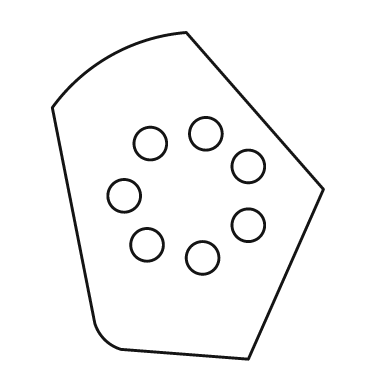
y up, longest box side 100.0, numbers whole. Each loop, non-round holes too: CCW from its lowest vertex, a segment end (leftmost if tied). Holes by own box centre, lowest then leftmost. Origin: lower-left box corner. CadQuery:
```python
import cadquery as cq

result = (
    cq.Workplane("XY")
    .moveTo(60.0, 0.0)
    .lineTo(83.0, 52.0)
    .lineTo(41.0, 100.0)
    .threePointArc((18.0, 93.0), (0.0, 77.0))
    .lineTo(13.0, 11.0)
    .threePointArc((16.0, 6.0), (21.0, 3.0))
    .close()
    .moveTo(46.0, 31.0)
    .circle(5.0)
    .moveTo(29.0, 35.0)
    .circle(5.0)
    .moveTo(60.0, 41.0)
    .circle(5.0)
    .moveTo(22.0, 50.0)
    .circle(5.0)
    .moveTo(60.0, 59.0)
    .circle(5.0)
    .moveTo(30.0, 66.0)
    .circle(5.0)
    .moveTo(47.0, 69.0)
    .circle(5.0)
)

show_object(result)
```